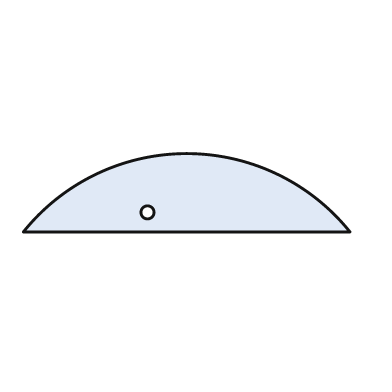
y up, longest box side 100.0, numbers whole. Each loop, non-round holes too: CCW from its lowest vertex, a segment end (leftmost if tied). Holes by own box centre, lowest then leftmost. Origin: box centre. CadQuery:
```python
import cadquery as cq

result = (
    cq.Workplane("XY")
    .moveTo(-50.0, -12.0)
    .lineTo(50.0, -12.0)
    .threePointArc((0.0, 12.0), (-50.0, -12.0))
    .close()
    .moveTo(-12.0, -6.0)
    .circle(2.0)
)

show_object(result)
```